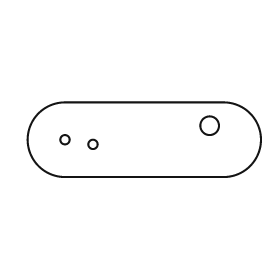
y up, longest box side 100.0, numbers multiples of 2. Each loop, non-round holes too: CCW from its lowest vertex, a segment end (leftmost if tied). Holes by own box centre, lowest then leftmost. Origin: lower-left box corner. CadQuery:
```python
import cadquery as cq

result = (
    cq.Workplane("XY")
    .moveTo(16.0, 0.0)
    .lineTo(84.0, 0.0)
    .threePointArc((100.0, 16.0), (84.0, 32.0))
    .lineTo(16.0, 32.0)
    .threePointArc((0.0, 16.0), (16.0, 0.0))
    .close()
    .moveTo(28.0, 14.0)
    .circle(2.0)
    .moveTo(16.0, 16.0)
    .circle(2.0)
    .moveTo(78.0, 22.0)
    .circle(4.0)
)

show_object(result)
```